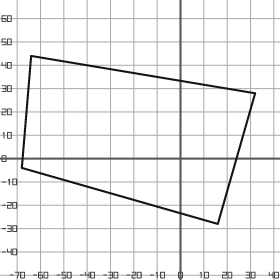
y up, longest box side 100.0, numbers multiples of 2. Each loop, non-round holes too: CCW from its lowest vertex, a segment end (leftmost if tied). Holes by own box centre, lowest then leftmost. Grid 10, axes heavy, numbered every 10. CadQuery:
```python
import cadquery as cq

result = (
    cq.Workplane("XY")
    .moveTo(16.0, -28.0)
    .lineTo(32.0, 28.0)
    .lineTo(-64.0, 44.0)
    .lineTo(-68.0, -4.0)
    .close()
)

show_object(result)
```